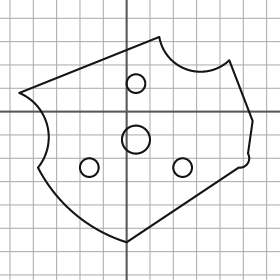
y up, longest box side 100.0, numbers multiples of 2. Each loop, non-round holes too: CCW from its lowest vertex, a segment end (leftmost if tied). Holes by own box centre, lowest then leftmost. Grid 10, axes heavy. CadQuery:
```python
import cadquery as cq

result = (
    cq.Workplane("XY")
    .moveTo(0.0, -56.0)
    .lineTo(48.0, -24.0)
    .threePointArc((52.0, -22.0), (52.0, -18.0))
    .lineTo(54.0, -4.0)
    .lineTo(44.0, 22.0)
    .threePointArc((26.0, 18.0), (14.0, 32.0))
    .lineTo(-46.0, 8.0)
    .threePointArc((-34.0, -6.0), (-38.0, -24.0))
    .threePointArc((-22.0, -44.0), (0.0, -56.0))
    .close()
    .moveTo(-16.0, -24.0)
    .circle(4.0)
    .moveTo(24.0, -24.0)
    .circle(4.0)
    .moveTo(4.0, -12.0)
    .circle(6.0)
    .moveTo(4.0, 12.0)
    .circle(4.0)
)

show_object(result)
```